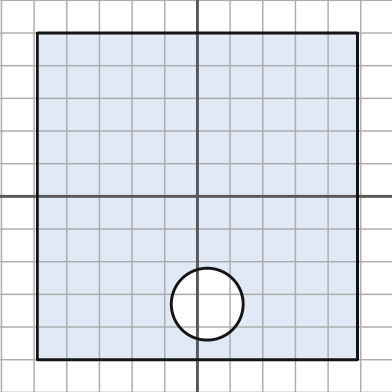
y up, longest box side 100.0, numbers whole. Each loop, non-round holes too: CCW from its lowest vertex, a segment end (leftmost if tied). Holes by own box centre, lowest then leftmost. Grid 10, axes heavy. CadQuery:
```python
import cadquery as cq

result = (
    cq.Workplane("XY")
    .moveTo(-49.0, -50.0)
    .lineTo(49.0, -50.0)
    .lineTo(49.0, 50.0)
    .lineTo(-49.0, 50.0)
    .close()
    .moveTo(3.0, -33.0)
    .circle(11.0)
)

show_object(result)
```